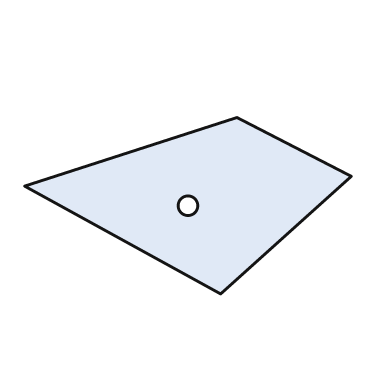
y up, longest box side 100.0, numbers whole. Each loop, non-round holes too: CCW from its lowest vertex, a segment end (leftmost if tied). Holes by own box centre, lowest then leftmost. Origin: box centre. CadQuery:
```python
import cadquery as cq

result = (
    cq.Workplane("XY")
    .moveTo(10.0, -27.0)
    .lineTo(50.0, 9.0)
    .lineTo(15.0, 27.0)
    .lineTo(-50.0, 6.0)
    .close()
    .moveTo(0.0, 0.0)
    .circle(3.0)
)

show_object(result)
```